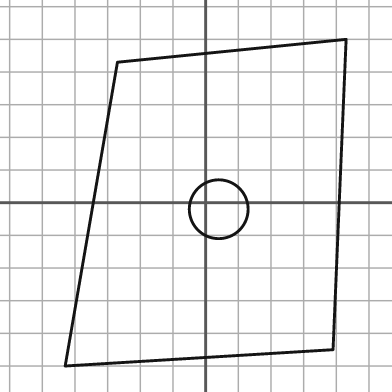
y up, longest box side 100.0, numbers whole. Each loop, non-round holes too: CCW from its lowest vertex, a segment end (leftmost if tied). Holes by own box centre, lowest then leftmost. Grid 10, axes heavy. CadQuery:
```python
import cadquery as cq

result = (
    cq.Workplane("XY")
    .moveTo(-43.0, -50.0)
    .lineTo(39.0, -45.0)
    .lineTo(43.0, 50.0)
    .lineTo(-27.0, 43.0)
    .close()
    .moveTo(4.0, -2.0)
    .circle(9.0)
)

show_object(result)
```